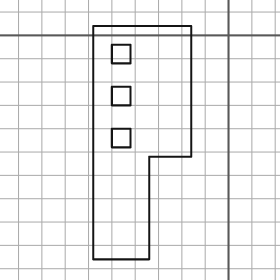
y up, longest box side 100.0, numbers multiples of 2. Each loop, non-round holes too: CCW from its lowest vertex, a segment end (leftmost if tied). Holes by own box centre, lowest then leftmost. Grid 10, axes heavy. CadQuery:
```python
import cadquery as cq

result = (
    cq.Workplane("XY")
    .moveTo(-58.0, -96.0)
    .lineTo(-34.0, -96.0)
    .lineTo(-34.0, -52.0)
    .lineTo(-16.0, -52.0)
    .lineTo(-16.0, 4.0)
    .lineTo(-58.0, 4.0)
    .close()
    .moveTo(-50.0, -48.0)
    .lineTo(-42.0, -48.0)
    .lineTo(-42.0, -40.0)
    .lineTo(-50.0, -40.0)
    .close()
    .moveTo(-50.0, -30.0)
    .lineTo(-42.0, -30.0)
    .lineTo(-42.0, -22.0)
    .lineTo(-50.0, -22.0)
    .close()
    .moveTo(-50.0, -12.0)
    .lineTo(-42.0, -12.0)
    .lineTo(-42.0, -4.0)
    .lineTo(-50.0, -4.0)
    .close()
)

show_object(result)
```